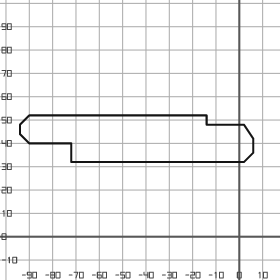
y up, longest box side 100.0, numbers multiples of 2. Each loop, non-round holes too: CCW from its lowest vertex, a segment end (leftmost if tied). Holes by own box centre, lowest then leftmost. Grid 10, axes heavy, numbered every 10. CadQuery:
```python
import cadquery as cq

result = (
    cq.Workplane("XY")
    .moveTo(-72.0, 32.0)
    .lineTo(2.0, 32.0)
    .lineTo(6.0, 36.0)
    .lineTo(6.0, 42.0)
    .lineTo(2.0, 48.0)
    .lineTo(-14.0, 48.0)
    .lineTo(-14.0, 52.0)
    .lineTo(-90.0, 52.0)
    .lineTo(-94.0, 48.0)
    .lineTo(-94.0, 44.0)
    .lineTo(-90.0, 40.0)
    .lineTo(-72.0, 40.0)
    .close()
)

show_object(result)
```